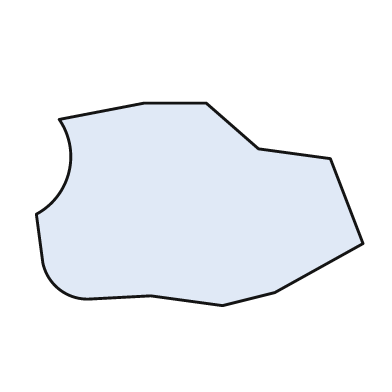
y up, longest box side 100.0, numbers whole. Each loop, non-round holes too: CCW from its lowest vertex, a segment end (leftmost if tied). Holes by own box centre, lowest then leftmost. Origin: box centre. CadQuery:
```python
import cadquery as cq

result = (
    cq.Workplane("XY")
    .moveTo(7.0, -31.0)
    .lineTo(23.0, -27.0)
    .lineTo(50.0, -12.0)
    .lineTo(40.0, 14.0)
    .lineTo(18.0, 17.0)
    .lineTo(2.0, 31.0)
    .lineTo(-17.0, 31.0)
    .lineTo(-43.0, 26.0)
    .threePointArc((-40.0, 10.0), (-50.0, -3.0))
    .lineTo(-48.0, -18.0)
    .threePointArc((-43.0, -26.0), (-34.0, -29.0))
    .lineTo(-15.0, -28.0)
    .close()
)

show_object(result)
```